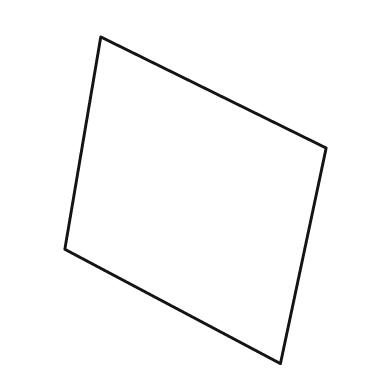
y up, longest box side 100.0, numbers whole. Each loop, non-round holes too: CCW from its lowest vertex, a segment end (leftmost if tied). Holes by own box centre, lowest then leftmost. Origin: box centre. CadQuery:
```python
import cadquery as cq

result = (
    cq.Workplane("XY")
    .moveTo(26.0, -50.0)
    .lineTo(40.0, 16.0)
    .lineTo(-29.0, 50.0)
    .lineTo(-40.0, -15.0)
    .close()
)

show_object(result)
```